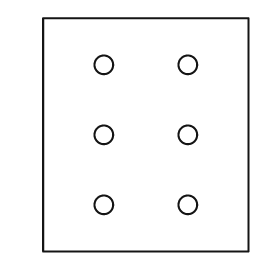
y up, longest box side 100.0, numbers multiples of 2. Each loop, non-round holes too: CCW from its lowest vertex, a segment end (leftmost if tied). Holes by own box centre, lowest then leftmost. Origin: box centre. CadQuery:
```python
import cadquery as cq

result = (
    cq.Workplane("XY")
    .moveTo(-44.0, -50.0)
    .lineTo(44.0, -50.0)
    .lineTo(44.0, 50.0)
    .lineTo(-44.0, 50.0)
    .close()
    .moveTo(-18.0, -30.0)
    .circle(4.0)
    .moveTo(18.0, -30.0)
    .circle(4.0)
    .moveTo(-18.0, 0.0)
    .circle(4.0)
    .moveTo(18.0, 0.0)
    .circle(4.0)
    .moveTo(-18.0, 30.0)
    .circle(4.0)
    .moveTo(18.0, 30.0)
    .circle(4.0)
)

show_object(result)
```